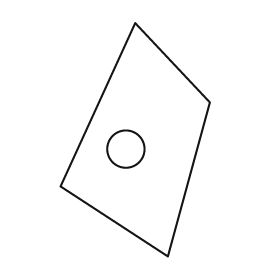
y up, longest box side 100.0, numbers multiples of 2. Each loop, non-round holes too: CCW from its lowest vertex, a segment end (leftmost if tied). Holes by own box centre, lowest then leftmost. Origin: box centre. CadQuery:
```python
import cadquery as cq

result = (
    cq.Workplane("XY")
    .moveTo(14.0, -50.0)
    .lineTo(32.0, 16.0)
    .lineTo(0.0, 50.0)
    .lineTo(-32.0, -20.0)
    .close()
    .moveTo(-4.0, -4.0)
    .circle(8.0)
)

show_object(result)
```